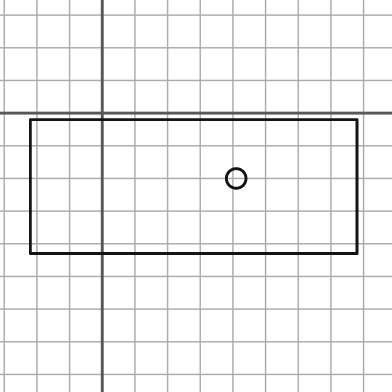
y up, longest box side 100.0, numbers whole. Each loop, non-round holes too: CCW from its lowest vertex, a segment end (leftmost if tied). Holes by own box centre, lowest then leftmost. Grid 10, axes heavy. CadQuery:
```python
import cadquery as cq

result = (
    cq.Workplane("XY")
    .moveTo(-22.0, -43.0)
    .lineTo(78.0, -43.0)
    .lineTo(78.0, -2.0)
    .lineTo(-22.0, -2.0)
    .close()
    .moveTo(41.0, -20.0)
    .circle(3.0)
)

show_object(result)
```